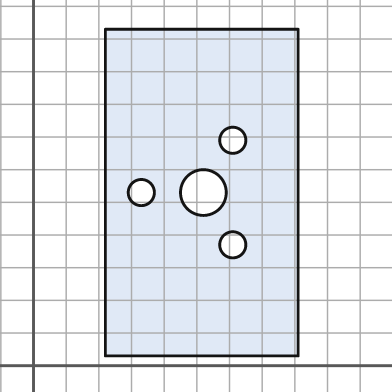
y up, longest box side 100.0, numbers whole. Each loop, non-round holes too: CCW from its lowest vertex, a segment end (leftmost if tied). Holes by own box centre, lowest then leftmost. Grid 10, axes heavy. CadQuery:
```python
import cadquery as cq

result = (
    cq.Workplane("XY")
    .moveTo(22.0, 3.0)
    .lineTo(81.0, 3.0)
    .lineTo(81.0, 103.0)
    .lineTo(22.0, 103.0)
    .close()
    .moveTo(61.0, 37.0)
    .circle(4.0)
    .moveTo(33.0, 53.0)
    .circle(4.0)
    .moveTo(52.0, 53.0)
    .circle(7.0)
    .moveTo(61.0, 69.0)
    .circle(4.0)
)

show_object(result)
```